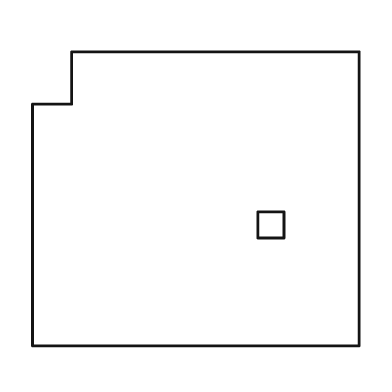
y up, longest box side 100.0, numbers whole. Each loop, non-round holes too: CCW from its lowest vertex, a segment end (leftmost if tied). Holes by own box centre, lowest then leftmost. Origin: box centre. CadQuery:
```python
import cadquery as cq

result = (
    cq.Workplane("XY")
    .moveTo(-50.0, -45.0)
    .lineTo(50.0, -45.0)
    .lineTo(50.0, 45.0)
    .lineTo(-38.0, 45.0)
    .lineTo(-38.0, 29.0)
    .lineTo(-50.0, 29.0)
    .close()
    .moveTo(19.0, -12.0)
    .lineTo(27.0, -12.0)
    .lineTo(27.0, -4.0)
    .lineTo(19.0, -4.0)
    .close()
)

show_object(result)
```